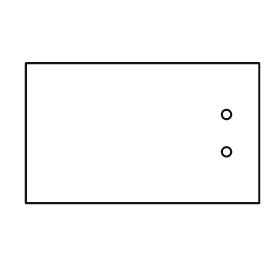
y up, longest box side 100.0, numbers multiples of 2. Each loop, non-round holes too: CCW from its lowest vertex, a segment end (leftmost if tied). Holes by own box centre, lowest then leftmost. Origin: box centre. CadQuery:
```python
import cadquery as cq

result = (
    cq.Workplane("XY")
    .moveTo(-50.0, -30.0)
    .lineTo(50.0, -30.0)
    .lineTo(50.0, 30.0)
    .lineTo(-50.0, 30.0)
    .close()
    .moveTo(36.0, -8.0)
    .circle(2.0)
    .moveTo(36.0, 8.0)
    .circle(2.0)
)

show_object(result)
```